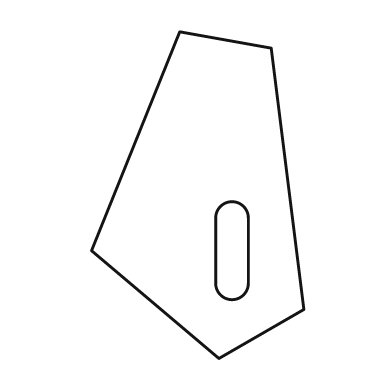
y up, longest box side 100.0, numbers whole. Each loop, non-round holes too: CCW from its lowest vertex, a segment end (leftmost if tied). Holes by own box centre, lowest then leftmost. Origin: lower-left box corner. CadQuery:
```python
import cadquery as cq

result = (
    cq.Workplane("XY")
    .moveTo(39.0, 0.0)
    .lineTo(65.0, 15.0)
    .lineTo(55.0, 95.0)
    .lineTo(27.0, 100.0)
    .lineTo(0.0, 33.0)
    .close()
    .moveTo(38.0, 23.0)
    .threePointArc((43.0, 18.0), (48.0, 23.0))
    .lineTo(48.0, 43.0)
    .threePointArc((43.0, 48.0), (38.0, 43.0))
    .close()
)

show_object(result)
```